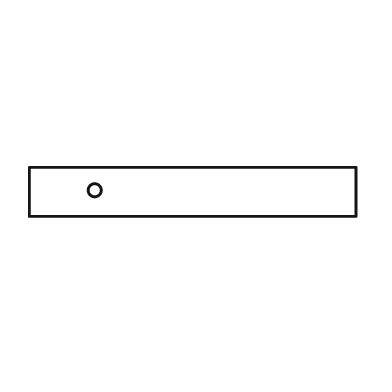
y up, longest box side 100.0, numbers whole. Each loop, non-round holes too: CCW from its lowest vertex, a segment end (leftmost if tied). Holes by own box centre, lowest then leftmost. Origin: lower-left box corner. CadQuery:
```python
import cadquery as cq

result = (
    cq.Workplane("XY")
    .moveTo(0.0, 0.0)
    .lineTo(100.0, 0.0)
    .lineTo(100.0, 15.0)
    .lineTo(0.0, 15.0)
    .close()
    .moveTo(20.0, 8.0)
    .circle(2.0)
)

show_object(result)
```